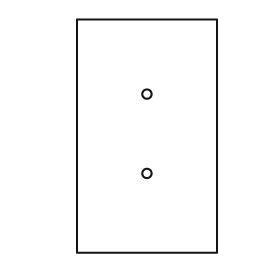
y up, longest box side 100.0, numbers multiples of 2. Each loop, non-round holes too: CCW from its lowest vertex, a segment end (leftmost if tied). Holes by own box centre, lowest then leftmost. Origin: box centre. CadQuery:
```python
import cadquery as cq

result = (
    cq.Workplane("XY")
    .moveTo(-30.0, -50.0)
    .lineTo(30.0, -50.0)
    .lineTo(30.0, 50.0)
    .lineTo(-30.0, 50.0)
    .close()
    .moveTo(0.0, -16.0)
    .circle(2.0)
    .moveTo(0.0, 18.0)
    .circle(2.0)
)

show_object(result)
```